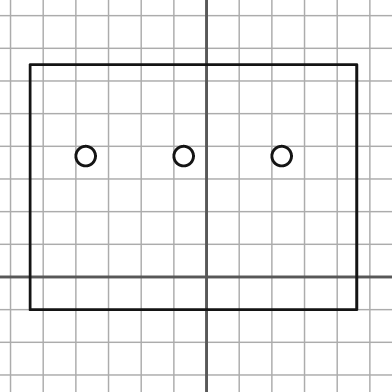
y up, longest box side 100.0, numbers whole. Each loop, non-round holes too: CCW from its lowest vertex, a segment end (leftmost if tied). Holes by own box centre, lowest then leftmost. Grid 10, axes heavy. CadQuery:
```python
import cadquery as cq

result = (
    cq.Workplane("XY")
    .moveTo(-54.0, -10.0)
    .lineTo(46.0, -10.0)
    .lineTo(46.0, 65.0)
    .lineTo(-54.0, 65.0)
    .close()
    .moveTo(-37.0, 37.0)
    .circle(3.0)
    .moveTo(-7.0, 37.0)
    .circle(3.0)
    .moveTo(23.0, 37.0)
    .circle(3.0)
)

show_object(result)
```